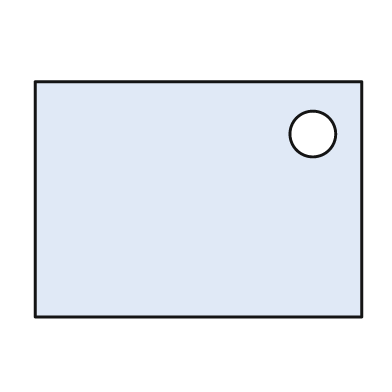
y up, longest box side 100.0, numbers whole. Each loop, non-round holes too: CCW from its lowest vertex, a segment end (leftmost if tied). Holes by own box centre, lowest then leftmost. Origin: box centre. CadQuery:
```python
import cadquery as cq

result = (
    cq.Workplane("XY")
    .moveTo(-50.0, -36.0)
    .lineTo(50.0, -36.0)
    .lineTo(50.0, 36.0)
    .lineTo(-50.0, 36.0)
    .close()
    .moveTo(35.0, 20.0)
    .circle(7.0)
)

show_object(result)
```